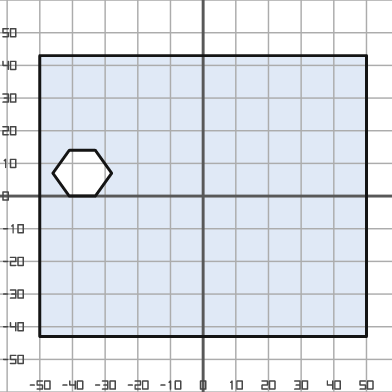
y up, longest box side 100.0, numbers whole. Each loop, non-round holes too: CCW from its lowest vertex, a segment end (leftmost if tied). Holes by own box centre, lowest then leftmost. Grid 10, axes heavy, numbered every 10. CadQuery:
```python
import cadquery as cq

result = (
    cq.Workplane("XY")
    .moveTo(-50.0, -43.0)
    .lineTo(50.0, -43.0)
    .lineTo(50.0, 43.0)
    .lineTo(-50.0, 43.0)
    .close()
    .moveTo(-41.0, 0.0)
    .lineTo(-33.0, 0.0)
    .lineTo(-28.0, 7.0)
    .lineTo(-33.0, 14.0)
    .lineTo(-41.0, 14.0)
    .lineTo(-46.0, 7.0)
    .close()
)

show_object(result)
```